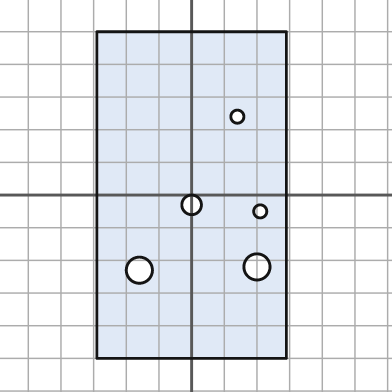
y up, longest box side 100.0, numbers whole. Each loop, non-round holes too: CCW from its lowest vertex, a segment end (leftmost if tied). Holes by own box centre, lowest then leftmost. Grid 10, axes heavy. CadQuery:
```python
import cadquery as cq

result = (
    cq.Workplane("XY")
    .moveTo(-29.0, -50.0)
    .lineTo(29.0, -50.0)
    .lineTo(29.0, 50.0)
    .lineTo(-29.0, 50.0)
    .close()
    .moveTo(-16.0, -23.0)
    .circle(4.0)
    .moveTo(20.0, -22.0)
    .circle(4.0)
    .moveTo(21.0, -5.0)
    .circle(2.0)
    .moveTo(0.0, -3.0)
    .circle(3.0)
    .moveTo(14.0, 24.0)
    .circle(2.0)
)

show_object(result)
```